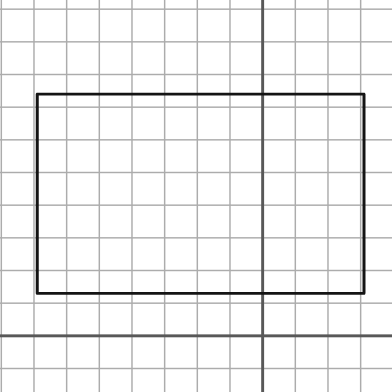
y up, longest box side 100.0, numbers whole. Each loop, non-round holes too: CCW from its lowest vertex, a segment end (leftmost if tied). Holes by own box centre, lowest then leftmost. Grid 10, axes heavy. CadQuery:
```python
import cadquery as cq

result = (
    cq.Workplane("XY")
    .moveTo(-69.0, 13.0)
    .lineTo(31.0, 13.0)
    .lineTo(31.0, 74.0)
    .lineTo(-69.0, 74.0)
    .close()
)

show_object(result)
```